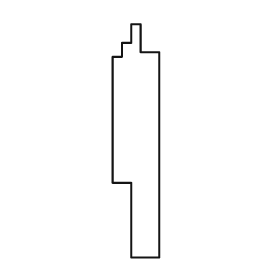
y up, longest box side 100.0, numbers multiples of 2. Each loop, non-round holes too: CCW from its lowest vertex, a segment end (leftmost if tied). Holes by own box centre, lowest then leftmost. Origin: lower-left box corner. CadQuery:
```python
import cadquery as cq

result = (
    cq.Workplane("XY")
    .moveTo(8.0, 0.0)
    .lineTo(20.0, 0.0)
    .lineTo(20.0, 88.0)
    .lineTo(12.0, 88.0)
    .lineTo(12.0, 100.0)
    .lineTo(8.0, 100.0)
    .lineTo(8.0, 92.0)
    .lineTo(4.0, 92.0)
    .lineTo(4.0, 86.0)
    .lineTo(0.0, 86.0)
    .lineTo(0.0, 32.0)
    .lineTo(8.0, 32.0)
    .close()
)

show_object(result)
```